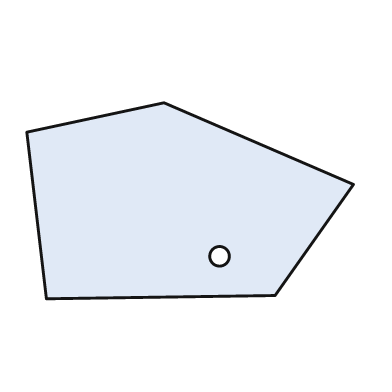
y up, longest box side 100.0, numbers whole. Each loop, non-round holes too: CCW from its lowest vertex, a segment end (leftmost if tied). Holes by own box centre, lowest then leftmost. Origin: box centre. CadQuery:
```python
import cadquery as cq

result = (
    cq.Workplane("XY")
    .moveTo(-44.0, -30.0)
    .lineTo(26.0, -29.0)
    .lineTo(50.0, 5.0)
    .lineTo(-8.0, 30.0)
    .lineTo(-50.0, 21.0)
    .close()
    .moveTo(9.0, -17.0)
    .circle(3.0)
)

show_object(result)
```